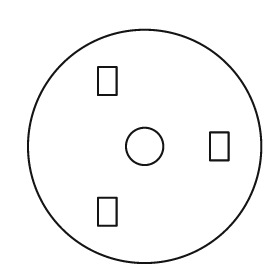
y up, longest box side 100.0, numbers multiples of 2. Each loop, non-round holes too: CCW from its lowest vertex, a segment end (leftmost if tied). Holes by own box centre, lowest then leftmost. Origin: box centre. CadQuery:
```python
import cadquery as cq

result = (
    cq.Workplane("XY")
    .moveTo(0.0, 0.0)
    .circle(50.0)
    .moveTo(-20.0, -34.0)
    .lineTo(-12.0, -34.0)
    .lineTo(-12.0, -22.0)
    .lineTo(-20.0, -22.0)
    .close()
    .moveTo(0.0, 0.0)
    .circle(8.0)
    .moveTo(28.0, -6.0)
    .lineTo(36.0, -6.0)
    .lineTo(36.0, 6.0)
    .lineTo(28.0, 6.0)
    .close()
    .moveTo(-20.0, 22.0)
    .lineTo(-12.0, 22.0)
    .lineTo(-12.0, 34.0)
    .lineTo(-20.0, 34.0)
    .close()
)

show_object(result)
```